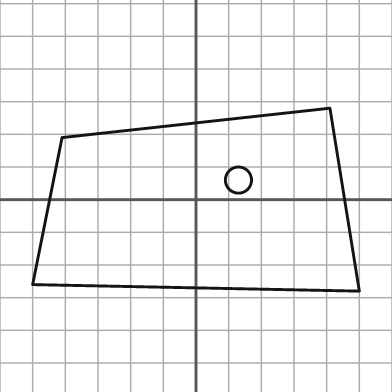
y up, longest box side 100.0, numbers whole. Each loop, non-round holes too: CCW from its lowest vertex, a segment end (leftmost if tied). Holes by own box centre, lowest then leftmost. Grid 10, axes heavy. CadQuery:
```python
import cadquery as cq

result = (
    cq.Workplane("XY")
    .moveTo(50.0, -28.0)
    .lineTo(41.0, 28.0)
    .lineTo(-41.0, 19.0)
    .lineTo(-50.0, -26.0)
    .close()
    .moveTo(13.0, 6.0)
    .circle(4.0)
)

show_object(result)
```